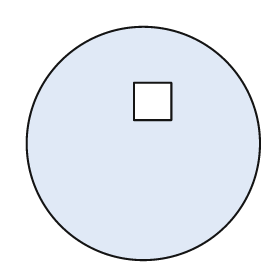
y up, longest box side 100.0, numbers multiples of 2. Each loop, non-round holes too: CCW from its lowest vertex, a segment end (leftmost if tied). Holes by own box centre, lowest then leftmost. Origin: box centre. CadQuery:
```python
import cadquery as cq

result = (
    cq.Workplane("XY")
    .moveTo(0.0, 0.0)
    .circle(50.0)
    .moveTo(-4.0, 10.0)
    .lineTo(12.0, 10.0)
    .lineTo(12.0, 26.0)
    .lineTo(-4.0, 26.0)
    .close()
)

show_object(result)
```